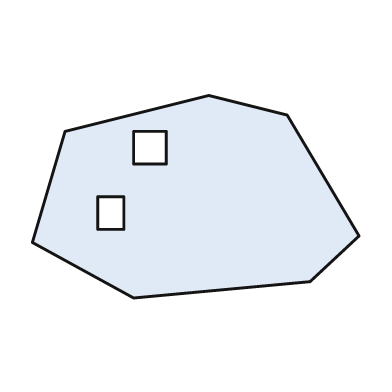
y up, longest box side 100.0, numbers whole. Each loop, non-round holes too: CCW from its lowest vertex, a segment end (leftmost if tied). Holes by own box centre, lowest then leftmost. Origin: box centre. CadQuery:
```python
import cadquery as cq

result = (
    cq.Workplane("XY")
    .moveTo(-19.0, -31.0)
    .lineTo(35.0, -26.0)
    .lineTo(50.0, -12.0)
    .lineTo(28.0, 25.0)
    .lineTo(4.0, 31.0)
    .lineTo(-40.0, 20.0)
    .lineTo(-50.0, -14.0)
    .close()
    .moveTo(-30.0, -10.0)
    .lineTo(-22.0, -10.0)
    .lineTo(-22.0, 0.0)
    .lineTo(-30.0, 0.0)
    .close()
    .moveTo(-19.0, 10.0)
    .lineTo(-9.0, 10.0)
    .lineTo(-9.0, 20.0)
    .lineTo(-19.0, 20.0)
    .close()
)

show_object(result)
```